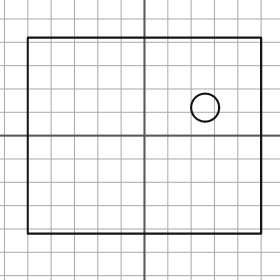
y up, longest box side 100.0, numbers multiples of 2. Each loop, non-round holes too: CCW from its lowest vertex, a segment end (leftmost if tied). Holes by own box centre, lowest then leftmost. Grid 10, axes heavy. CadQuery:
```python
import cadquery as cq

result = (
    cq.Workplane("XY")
    .moveTo(-50.0, -42.0)
    .lineTo(50.0, -42.0)
    .lineTo(50.0, 42.0)
    .lineTo(-50.0, 42.0)
    .close()
    .moveTo(26.0, 12.0)
    .circle(6.0)
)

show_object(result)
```